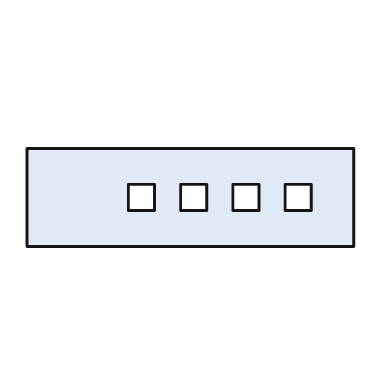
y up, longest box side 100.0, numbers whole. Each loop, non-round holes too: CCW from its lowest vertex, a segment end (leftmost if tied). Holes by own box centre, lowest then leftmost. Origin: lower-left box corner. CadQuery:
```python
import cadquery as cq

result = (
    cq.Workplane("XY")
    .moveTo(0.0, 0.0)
    .lineTo(100.0, 0.0)
    .lineTo(100.0, 30.0)
    .lineTo(0.0, 30.0)
    .close()
    .moveTo(31.0, 11.0)
    .lineTo(39.0, 11.0)
    .lineTo(39.0, 19.0)
    .lineTo(31.0, 19.0)
    .close()
    .moveTo(47.0, 11.0)
    .lineTo(55.0, 11.0)
    .lineTo(55.0, 19.0)
    .lineTo(47.0, 19.0)
    .close()
    .moveTo(63.0, 11.0)
    .lineTo(71.0, 11.0)
    .lineTo(71.0, 19.0)
    .lineTo(63.0, 19.0)
    .close()
    .moveTo(79.0, 11.0)
    .lineTo(87.0, 11.0)
    .lineTo(87.0, 19.0)
    .lineTo(79.0, 19.0)
    .close()
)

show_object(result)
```